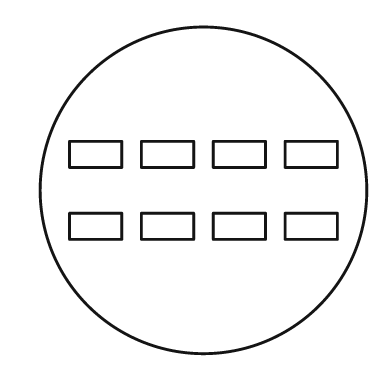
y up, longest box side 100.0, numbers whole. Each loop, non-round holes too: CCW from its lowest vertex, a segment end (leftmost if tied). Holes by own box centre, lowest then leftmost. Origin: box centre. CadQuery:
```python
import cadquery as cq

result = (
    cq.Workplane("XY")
    .moveTo(0.0, 0.0)
    .circle(50.0)
    .moveTo(-41.0, -15.0)
    .lineTo(-25.0, -15.0)
    .lineTo(-25.0, -7.0)
    .lineTo(-41.0, -7.0)
    .close()
    .moveTo(-19.0, -15.0)
    .lineTo(-3.0, -15.0)
    .lineTo(-3.0, -7.0)
    .lineTo(-19.0, -7.0)
    .close()
    .moveTo(3.0, -15.0)
    .lineTo(19.0, -15.0)
    .lineTo(19.0, -7.0)
    .lineTo(3.0, -7.0)
    .close()
    .moveTo(25.0, -15.0)
    .lineTo(41.0, -15.0)
    .lineTo(41.0, -7.0)
    .lineTo(25.0, -7.0)
    .close()
    .moveTo(-41.0, 7.0)
    .lineTo(-25.0, 7.0)
    .lineTo(-25.0, 15.0)
    .lineTo(-41.0, 15.0)
    .close()
    .moveTo(-19.0, 7.0)
    .lineTo(-3.0, 7.0)
    .lineTo(-3.0, 15.0)
    .lineTo(-19.0, 15.0)
    .close()
    .moveTo(3.0, 7.0)
    .lineTo(19.0, 7.0)
    .lineTo(19.0, 15.0)
    .lineTo(3.0, 15.0)
    .close()
    .moveTo(25.0, 7.0)
    .lineTo(41.0, 7.0)
    .lineTo(41.0, 15.0)
    .lineTo(25.0, 15.0)
    .close()
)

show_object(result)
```